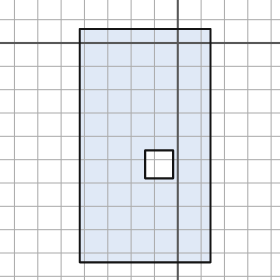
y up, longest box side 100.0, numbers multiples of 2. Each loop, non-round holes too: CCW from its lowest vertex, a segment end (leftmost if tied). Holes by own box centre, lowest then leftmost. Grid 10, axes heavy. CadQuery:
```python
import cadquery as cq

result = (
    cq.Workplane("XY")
    .moveTo(-42.0, -94.0)
    .lineTo(14.0, -94.0)
    .lineTo(14.0, 6.0)
    .lineTo(-42.0, 6.0)
    .close()
    .moveTo(-14.0, -58.0)
    .lineTo(-2.0, -58.0)
    .lineTo(-2.0, -46.0)
    .lineTo(-14.0, -46.0)
    .close()
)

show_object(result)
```